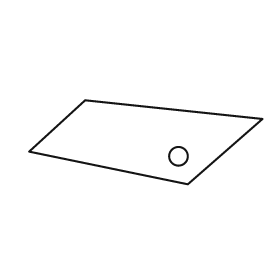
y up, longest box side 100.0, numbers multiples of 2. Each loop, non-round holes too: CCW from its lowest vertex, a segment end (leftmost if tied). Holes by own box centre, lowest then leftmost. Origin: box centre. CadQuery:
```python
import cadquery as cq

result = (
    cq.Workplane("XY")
    .moveTo(18.0, -18.0)
    .lineTo(50.0, 10.0)
    .lineTo(-26.0, 18.0)
    .lineTo(-50.0, -4.0)
    .close()
    .moveTo(14.0, -6.0)
    .circle(4.0)
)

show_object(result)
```